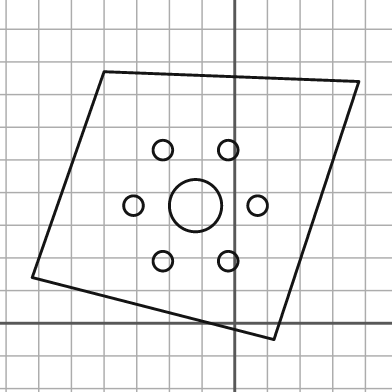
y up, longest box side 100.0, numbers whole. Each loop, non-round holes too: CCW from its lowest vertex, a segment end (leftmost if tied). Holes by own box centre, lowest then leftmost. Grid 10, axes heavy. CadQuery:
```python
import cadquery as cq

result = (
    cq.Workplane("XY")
    .moveTo(12.0, -5.0)
    .lineTo(38.0, 74.0)
    .lineTo(-40.0, 77.0)
    .lineTo(-62.0, 14.0)
    .close()
    .moveTo(-22.0, 19.0)
    .circle(3.0)
    .moveTo(-2.0, 19.0)
    .circle(3.0)
    .moveTo(-31.0, 36.0)
    .circle(3.0)
    .moveTo(-12.0, 36.0)
    .circle(8.0)
    .moveTo(7.0, 36.0)
    .circle(3.0)
    .moveTo(-22.0, 53.0)
    .circle(3.0)
    .moveTo(-2.0, 53.0)
    .circle(3.0)
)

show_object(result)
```